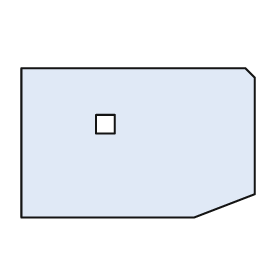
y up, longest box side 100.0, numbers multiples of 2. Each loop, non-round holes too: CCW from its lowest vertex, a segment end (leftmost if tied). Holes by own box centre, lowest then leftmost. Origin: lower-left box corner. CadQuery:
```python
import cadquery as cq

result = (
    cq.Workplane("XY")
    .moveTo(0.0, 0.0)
    .lineTo(74.0, 0.0)
    .lineTo(100.0, 10.0)
    .lineTo(100.0, 60.0)
    .lineTo(96.0, 64.0)
    .lineTo(0.0, 64.0)
    .close()
    .moveTo(32.0, 36.0)
    .lineTo(40.0, 36.0)
    .lineTo(40.0, 44.0)
    .lineTo(32.0, 44.0)
    .close()
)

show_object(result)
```